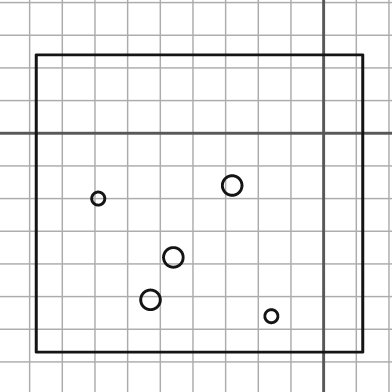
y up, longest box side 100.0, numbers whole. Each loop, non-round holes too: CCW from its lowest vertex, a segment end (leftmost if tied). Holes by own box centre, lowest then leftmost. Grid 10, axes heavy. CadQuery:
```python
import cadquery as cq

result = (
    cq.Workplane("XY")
    .moveTo(-88.0, -67.0)
    .lineTo(12.0, -67.0)
    .lineTo(12.0, 24.0)
    .lineTo(-88.0, 24.0)
    .close()
    .moveTo(-16.0, -56.0)
    .circle(2.0)
    .moveTo(-53.0, -51.0)
    .circle(3.0)
    .moveTo(-46.0, -38.0)
    .circle(3.0)
    .moveTo(-69.0, -20.0)
    .circle(2.0)
    .moveTo(-28.0, -16.0)
    .circle(3.0)
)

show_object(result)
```